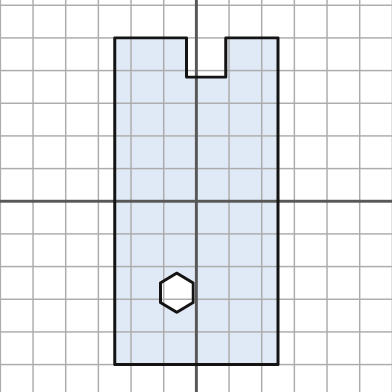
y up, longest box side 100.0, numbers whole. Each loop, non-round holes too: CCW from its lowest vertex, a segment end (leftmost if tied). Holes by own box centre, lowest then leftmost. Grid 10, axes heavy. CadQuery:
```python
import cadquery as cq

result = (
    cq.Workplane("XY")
    .moveTo(-25.0, -50.0)
    .lineTo(25.0, -50.0)
    .lineTo(25.0, 50.0)
    .lineTo(9.0, 50.0)
    .lineTo(9.0, 38.0)
    .lineTo(-3.0, 38.0)
    .lineTo(-3.0, 50.0)
    .lineTo(-25.0, 50.0)
    .close()
    .moveTo(-6.0, -34.0)
    .lineTo(-1.0, -31.0)
    .lineTo(-1.0, -25.0)
    .lineTo(-6.0, -22.0)
    .lineTo(-11.0, -25.0)
    .lineTo(-11.0, -31.0)
    .close()
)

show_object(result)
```